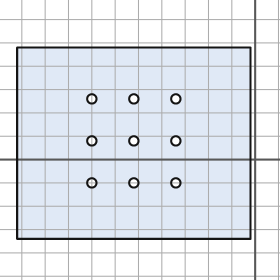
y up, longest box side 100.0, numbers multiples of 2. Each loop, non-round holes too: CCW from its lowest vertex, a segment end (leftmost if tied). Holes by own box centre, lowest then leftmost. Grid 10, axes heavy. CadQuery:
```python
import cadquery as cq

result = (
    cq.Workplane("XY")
    .moveTo(-102.0, -34.0)
    .lineTo(-2.0, -34.0)
    .lineTo(-2.0, 48.0)
    .lineTo(-102.0, 48.0)
    .close()
    .moveTo(-70.0, -10.0)
    .circle(2.0)
    .moveTo(-52.0, -10.0)
    .circle(2.0)
    .moveTo(-34.0, -10.0)
    .circle(2.0)
    .moveTo(-70.0, 8.0)
    .circle(2.0)
    .moveTo(-52.0, 8.0)
    .circle(2.0)
    .moveTo(-34.0, 8.0)
    .circle(2.0)
    .moveTo(-70.0, 26.0)
    .circle(2.0)
    .moveTo(-52.0, 26.0)
    .circle(2.0)
    .moveTo(-34.0, 26.0)
    .circle(2.0)
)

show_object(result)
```